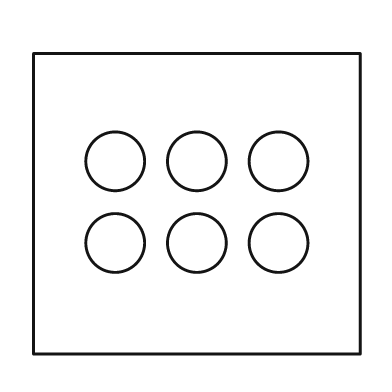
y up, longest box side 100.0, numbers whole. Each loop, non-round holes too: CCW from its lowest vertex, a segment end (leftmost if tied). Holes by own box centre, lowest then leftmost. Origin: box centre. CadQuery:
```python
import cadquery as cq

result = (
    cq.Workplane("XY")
    .moveTo(-50.0, -46.0)
    .lineTo(50.0, -46.0)
    .lineTo(50.0, 46.0)
    .lineTo(-50.0, 46.0)
    .close()
    .moveTo(-25.0, -12.0)
    .circle(9.0)
    .moveTo(0.0, -12.0)
    .circle(9.0)
    .moveTo(25.0, -12.0)
    .circle(9.0)
    .moveTo(-25.0, 13.0)
    .circle(9.0)
    .moveTo(0.0, 13.0)
    .circle(9.0)
    .moveTo(25.0, 13.0)
    .circle(9.0)
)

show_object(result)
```